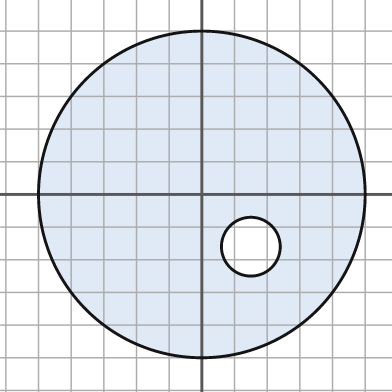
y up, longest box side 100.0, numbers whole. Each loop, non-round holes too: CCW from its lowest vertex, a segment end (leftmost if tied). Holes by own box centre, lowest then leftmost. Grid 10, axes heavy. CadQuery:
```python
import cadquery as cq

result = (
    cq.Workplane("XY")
    .moveTo(0.0, 0.0)
    .circle(50.0)
    .moveTo(15.0, -16.0)
    .circle(9.0)
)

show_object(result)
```